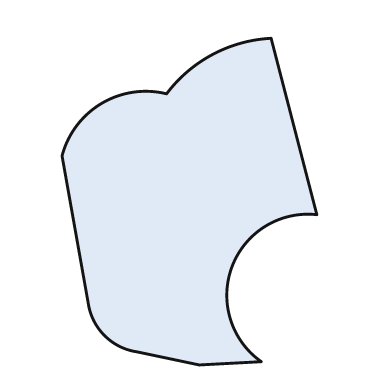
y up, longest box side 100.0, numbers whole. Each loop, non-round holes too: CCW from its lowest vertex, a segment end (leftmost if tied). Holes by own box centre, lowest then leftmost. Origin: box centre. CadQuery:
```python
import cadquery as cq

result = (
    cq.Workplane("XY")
    .moveTo(3.0, -50.0)
    .lineTo(22.0, -49.0)
    .threePointArc((13.0, -20.0), (39.0, -4.0))
    .lineTo(25.0, 50.0)
    .threePointArc((7.0, 45.0), (-7.0, 33.0))
    .threePointArc((-27.0, 30.0), (-39.0, 14.0))
    .lineTo(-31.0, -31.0)
    .threePointArc((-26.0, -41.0), (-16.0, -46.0))
    .close()
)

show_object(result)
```